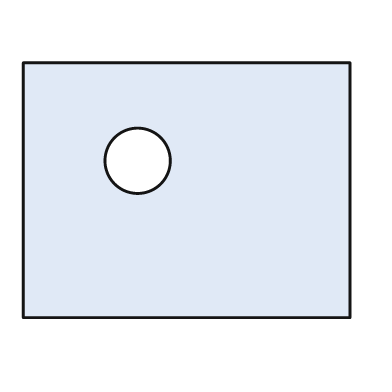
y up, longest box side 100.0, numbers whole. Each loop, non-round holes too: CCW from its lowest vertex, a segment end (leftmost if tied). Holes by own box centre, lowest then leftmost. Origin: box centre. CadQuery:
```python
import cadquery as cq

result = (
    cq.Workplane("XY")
    .moveTo(-50.0, -39.0)
    .lineTo(50.0, -39.0)
    .lineTo(50.0, 39.0)
    .lineTo(-50.0, 39.0)
    .close()
    .moveTo(-15.0, 9.0)
    .circle(10.0)
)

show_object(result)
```